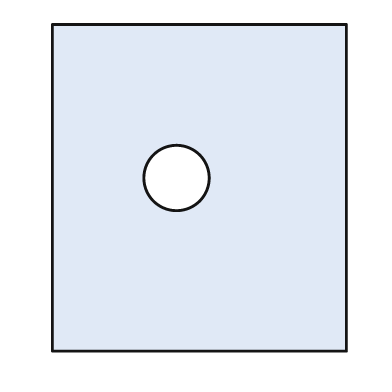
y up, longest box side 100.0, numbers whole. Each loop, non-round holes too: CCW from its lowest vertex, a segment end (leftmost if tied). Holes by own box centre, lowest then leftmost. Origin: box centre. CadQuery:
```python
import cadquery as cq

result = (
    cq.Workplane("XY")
    .moveTo(-45.0, -50.0)
    .lineTo(45.0, -50.0)
    .lineTo(45.0, 50.0)
    .lineTo(-45.0, 50.0)
    .close()
    .moveTo(-7.0, 3.0)
    .circle(10.0)
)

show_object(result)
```